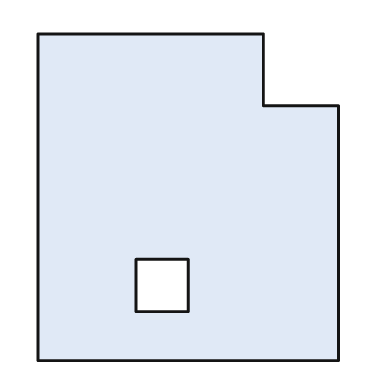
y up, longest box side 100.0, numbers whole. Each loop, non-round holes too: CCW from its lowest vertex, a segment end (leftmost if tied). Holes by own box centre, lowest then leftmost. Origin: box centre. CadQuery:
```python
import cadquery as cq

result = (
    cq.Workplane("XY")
    .moveTo(-46.0, -50.0)
    .lineTo(46.0, -50.0)
    .lineTo(46.0, 28.0)
    .lineTo(23.0, 28.0)
    .lineTo(23.0, 50.0)
    .lineTo(-46.0, 50.0)
    .close()
    .moveTo(-16.0, -35.0)
    .lineTo(0.0, -35.0)
    .lineTo(0.0, -19.0)
    .lineTo(-16.0, -19.0)
    .close()
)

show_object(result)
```